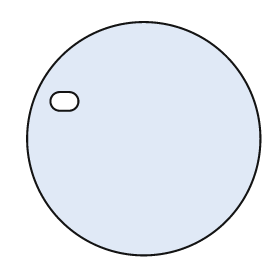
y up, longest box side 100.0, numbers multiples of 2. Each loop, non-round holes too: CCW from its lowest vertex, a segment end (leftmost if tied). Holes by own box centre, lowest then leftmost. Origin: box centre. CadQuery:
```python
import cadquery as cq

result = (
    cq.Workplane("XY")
    .moveTo(0.0, 0.0)
    .circle(50.0)
    .moveTo(-36.0, 12.0)
    .lineTo(-32.0, 12.0)
    .threePointArc((-28.0, 16.0), (-32.0, 20.0))
    .lineTo(-36.0, 20.0)
    .threePointArc((-40.0, 16.0), (-36.0, 12.0))
    .close()
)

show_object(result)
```